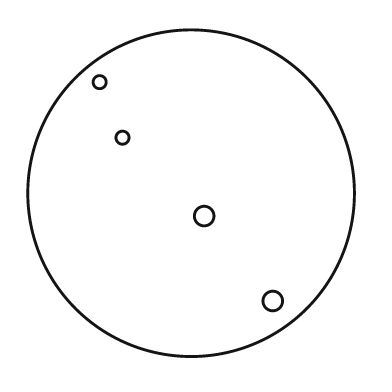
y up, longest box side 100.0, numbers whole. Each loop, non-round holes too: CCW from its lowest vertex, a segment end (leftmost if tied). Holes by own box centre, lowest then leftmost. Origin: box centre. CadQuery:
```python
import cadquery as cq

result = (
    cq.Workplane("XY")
    .moveTo(0.0, 0.0)
    .circle(50.0)
    .moveTo(25.0, -33.0)
    .circle(3.0)
    .moveTo(4.0, -7.0)
    .circle(3.0)
    .moveTo(-21.0, 17.0)
    .circle(2.0)
    .moveTo(-28.0, 34.0)
    .circle(2.0)
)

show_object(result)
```